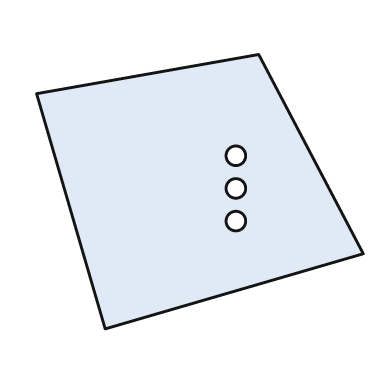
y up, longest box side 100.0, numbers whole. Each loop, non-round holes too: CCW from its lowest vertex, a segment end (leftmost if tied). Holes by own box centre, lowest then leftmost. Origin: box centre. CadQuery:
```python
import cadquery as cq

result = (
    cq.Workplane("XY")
    .moveTo(-29.0, -42.0)
    .lineTo(50.0, -19.0)
    .lineTo(18.0, 42.0)
    .lineTo(-50.0, 30.0)
    .close()
    .moveTo(11.0, -9.0)
    .circle(3.0)
    .moveTo(11.0, 1.0)
    .circle(3.0)
    .moveTo(11.0, 11.0)
    .circle(3.0)
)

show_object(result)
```